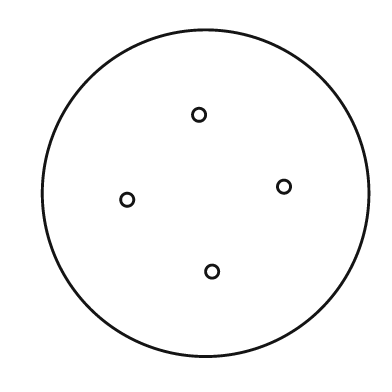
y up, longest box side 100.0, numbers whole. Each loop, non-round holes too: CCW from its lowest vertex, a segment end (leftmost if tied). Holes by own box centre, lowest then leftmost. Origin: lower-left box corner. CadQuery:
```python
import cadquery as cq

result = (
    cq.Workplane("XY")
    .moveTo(50.0, 50.0)
    .circle(50.0)
    .moveTo(52.0, 26.0)
    .circle(2.0)
    .moveTo(26.0, 48.0)
    .circle(2.0)
    .moveTo(74.0, 52.0)
    .circle(2.0)
    .moveTo(48.0, 74.0)
    .circle(2.0)
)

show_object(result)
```